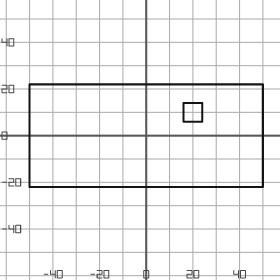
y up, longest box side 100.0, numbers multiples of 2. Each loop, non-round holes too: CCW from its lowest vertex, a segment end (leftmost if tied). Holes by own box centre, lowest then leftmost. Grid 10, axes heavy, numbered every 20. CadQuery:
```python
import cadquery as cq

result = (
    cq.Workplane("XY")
    .moveTo(-50.0, -22.0)
    .lineTo(50.0, -22.0)
    .lineTo(50.0, 22.0)
    .lineTo(-50.0, 22.0)
    .close()
    .moveTo(16.0, 6.0)
    .lineTo(24.0, 6.0)
    .lineTo(24.0, 14.0)
    .lineTo(16.0, 14.0)
    .close()
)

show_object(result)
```